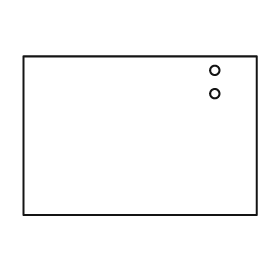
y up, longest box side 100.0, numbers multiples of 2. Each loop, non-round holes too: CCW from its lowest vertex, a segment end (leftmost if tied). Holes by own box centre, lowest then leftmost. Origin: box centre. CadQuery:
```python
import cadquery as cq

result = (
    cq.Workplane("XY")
    .moveTo(-50.0, -34.0)
    .lineTo(50.0, -34.0)
    .lineTo(50.0, 34.0)
    .lineTo(-50.0, 34.0)
    .close()
    .moveTo(32.0, 18.0)
    .circle(2.0)
    .moveTo(32.0, 28.0)
    .circle(2.0)
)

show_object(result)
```